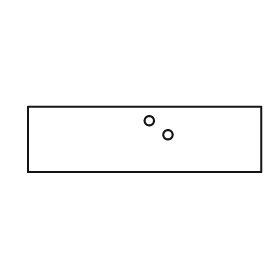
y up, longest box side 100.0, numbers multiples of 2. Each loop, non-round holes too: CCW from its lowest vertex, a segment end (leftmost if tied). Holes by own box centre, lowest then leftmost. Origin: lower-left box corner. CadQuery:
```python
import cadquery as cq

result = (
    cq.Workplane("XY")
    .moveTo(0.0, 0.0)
    .lineTo(100.0, 0.0)
    .lineTo(100.0, 28.0)
    .lineTo(0.0, 28.0)
    .close()
    .moveTo(60.0, 16.0)
    .circle(2.0)
    .moveTo(52.0, 22.0)
    .circle(2.0)
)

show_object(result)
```